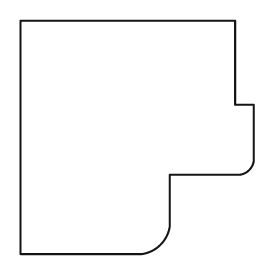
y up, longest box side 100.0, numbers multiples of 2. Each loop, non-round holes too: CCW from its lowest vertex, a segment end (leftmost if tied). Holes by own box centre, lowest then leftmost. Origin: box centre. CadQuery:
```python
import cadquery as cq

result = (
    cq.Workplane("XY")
    .moveTo(-50.0, -50.0)
    .lineTo(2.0, -50.0)
    .threePointArc((10.0, -46.0), (14.0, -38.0))
    .lineTo(14.0, -16.0)
    .lineTo(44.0, -16.0)
    .threePointArc((48.0, -14.0), (50.0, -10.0))
    .lineTo(50.0, 14.0)
    .lineTo(42.0, 14.0)
    .lineTo(42.0, 50.0)
    .lineTo(-50.0, 50.0)
    .close()
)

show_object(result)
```